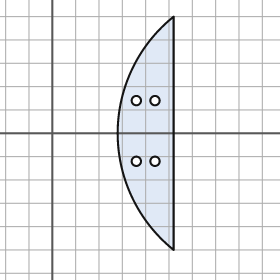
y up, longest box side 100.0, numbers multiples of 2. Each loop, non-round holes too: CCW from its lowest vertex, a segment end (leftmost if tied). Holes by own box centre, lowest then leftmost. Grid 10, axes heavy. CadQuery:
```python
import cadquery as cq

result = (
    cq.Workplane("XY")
    .moveTo(52.0, -50.0)
    .lineTo(52.0, 50.0)
    .threePointArc((28.0, 0.0), (52.0, -50.0))
    .close()
    .moveTo(36.0, -12.0)
    .circle(2.0)
    .moveTo(44.0, -12.0)
    .circle(2.0)
    .moveTo(36.0, 14.0)
    .circle(2.0)
    .moveTo(44.0, 14.0)
    .circle(2.0)
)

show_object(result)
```